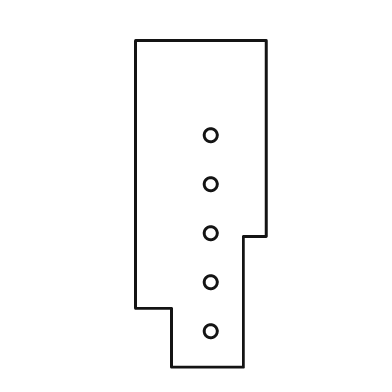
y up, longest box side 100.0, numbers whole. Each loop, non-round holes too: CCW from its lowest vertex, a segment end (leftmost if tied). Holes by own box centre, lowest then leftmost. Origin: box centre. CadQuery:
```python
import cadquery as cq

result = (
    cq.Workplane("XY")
    .moveTo(-9.0, -50.0)
    .lineTo(13.0, -50.0)
    .lineTo(13.0, -10.0)
    .lineTo(20.0, -10.0)
    .lineTo(20.0, 50.0)
    .lineTo(-20.0, 50.0)
    .lineTo(-20.0, -32.0)
    .lineTo(-9.0, -32.0)
    .close()
    .moveTo(3.0, -39.0)
    .circle(2.0)
    .moveTo(3.0, -24.0)
    .circle(2.0)
    .moveTo(3.0, -9.0)
    .circle(2.0)
    .moveTo(3.0, 6.0)
    .circle(2.0)
    .moveTo(3.0, 21.0)
    .circle(2.0)
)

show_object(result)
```